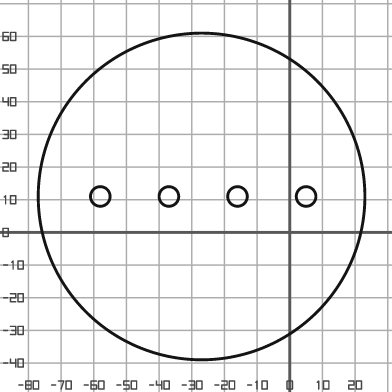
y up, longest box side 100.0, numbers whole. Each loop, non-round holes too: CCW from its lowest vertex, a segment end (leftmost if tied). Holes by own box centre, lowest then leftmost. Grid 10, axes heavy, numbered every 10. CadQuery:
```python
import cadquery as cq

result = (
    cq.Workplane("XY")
    .moveTo(-27.0, 11.0)
    .circle(50.0)
    .moveTo(-58.0, 11.0)
    .circle(3.0)
    .moveTo(-37.0, 11.0)
    .circle(3.0)
    .moveTo(-16.0, 11.0)
    .circle(3.0)
    .moveTo(5.0, 11.0)
    .circle(3.0)
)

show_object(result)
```